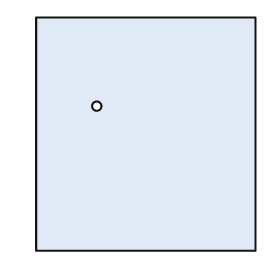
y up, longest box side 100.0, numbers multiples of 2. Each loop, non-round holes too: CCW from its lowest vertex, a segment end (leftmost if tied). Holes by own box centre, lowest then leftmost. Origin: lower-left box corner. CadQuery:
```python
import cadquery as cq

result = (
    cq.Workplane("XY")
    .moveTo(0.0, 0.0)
    .lineTo(94.0, 0.0)
    .lineTo(94.0, 100.0)
    .lineTo(0.0, 100.0)
    .close()
    .moveTo(26.0, 62.0)
    .circle(2.0)
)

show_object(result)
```